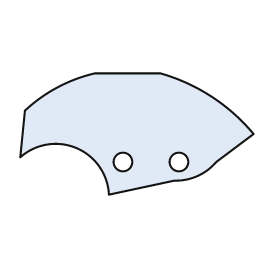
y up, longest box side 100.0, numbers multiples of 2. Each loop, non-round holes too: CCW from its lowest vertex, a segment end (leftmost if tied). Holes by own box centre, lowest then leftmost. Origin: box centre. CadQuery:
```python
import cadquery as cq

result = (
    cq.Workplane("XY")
    .moveTo(-12.0, -26.0)
    .lineTo(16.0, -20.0)
    .threePointArc((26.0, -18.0), (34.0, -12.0))
    .lineTo(50.0, 0.0)
    .threePointArc((32.0, 16.0), (10.0, 26.0))
    .lineTo(-18.0, 26.0)
    .threePointArc((-34.0, 20.0), (-48.0, 10.0))
    .lineTo(-50.0, -10.0)
    .threePointArc((-26.0, -6.0), (-12.0, -26.0))
    .close()
    .moveTo(-6.0, -12.0)
    .circle(4.0)
    .moveTo(18.0, -12.0)
    .circle(4.0)
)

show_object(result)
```